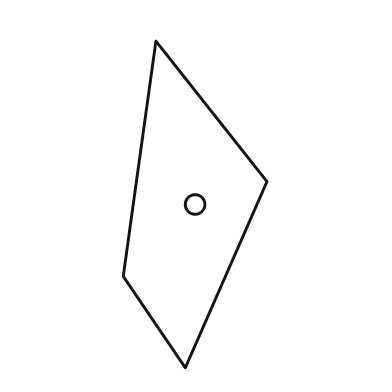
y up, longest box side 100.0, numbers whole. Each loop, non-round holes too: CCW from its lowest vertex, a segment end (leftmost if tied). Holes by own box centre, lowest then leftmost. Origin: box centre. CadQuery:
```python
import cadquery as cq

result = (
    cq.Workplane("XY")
    .moveTo(-3.0, -50.0)
    .lineTo(22.0, 7.0)
    .lineTo(-12.0, 50.0)
    .lineTo(-22.0, -22.0)
    .close()
    .moveTo(0.0, 0.0)
    .circle(3.0)
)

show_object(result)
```